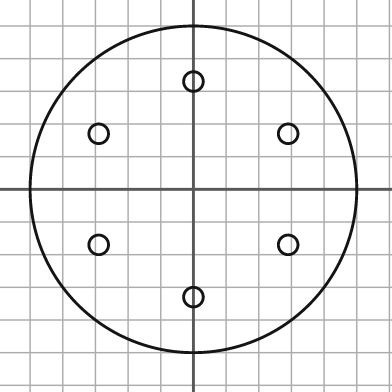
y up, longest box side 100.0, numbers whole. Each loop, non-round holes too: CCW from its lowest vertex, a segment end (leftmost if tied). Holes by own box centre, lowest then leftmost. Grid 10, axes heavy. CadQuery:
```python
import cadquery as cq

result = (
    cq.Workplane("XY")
    .moveTo(0.0, 0.0)
    .circle(50.0)
    .moveTo(0.0, -33.0)
    .circle(3.0)
    .moveTo(-29.0, -17.0)
    .circle(3.0)
    .moveTo(29.0, -17.0)
    .circle(3.0)
    .moveTo(-29.0, 17.0)
    .circle(3.0)
    .moveTo(29.0, 17.0)
    .circle(3.0)
    .moveTo(0.0, 33.0)
    .circle(3.0)
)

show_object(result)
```